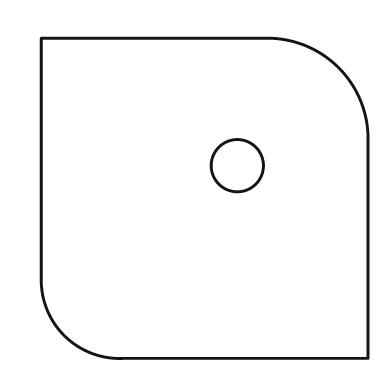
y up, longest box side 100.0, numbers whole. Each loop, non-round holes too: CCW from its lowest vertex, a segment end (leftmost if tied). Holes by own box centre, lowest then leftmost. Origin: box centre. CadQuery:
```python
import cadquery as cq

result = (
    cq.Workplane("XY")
    .moveTo(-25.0, -49.0)
    .lineTo(50.0, -49.0)
    .lineTo(50.0, 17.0)
    .threePointArc((41.0, 40.0), (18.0, 49.0))
    .lineTo(-50.0, 49.0)
    .lineTo(-50.0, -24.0)
    .threePointArc((-43.0, -42.0), (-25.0, -49.0))
    .close()
    .moveTo(10.0, 10.0)
    .circle(8.0)
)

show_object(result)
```